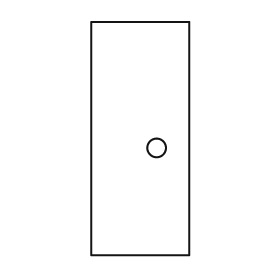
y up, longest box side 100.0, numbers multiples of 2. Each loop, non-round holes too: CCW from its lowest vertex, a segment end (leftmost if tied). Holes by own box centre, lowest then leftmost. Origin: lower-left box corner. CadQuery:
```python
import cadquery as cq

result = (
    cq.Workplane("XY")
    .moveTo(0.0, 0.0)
    .lineTo(42.0, 0.0)
    .lineTo(42.0, 100.0)
    .lineTo(0.0, 100.0)
    .close()
    .moveTo(28.0, 46.0)
    .circle(4.0)
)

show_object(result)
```